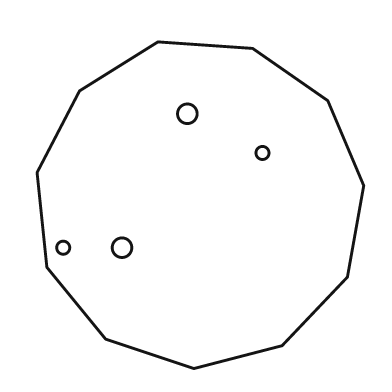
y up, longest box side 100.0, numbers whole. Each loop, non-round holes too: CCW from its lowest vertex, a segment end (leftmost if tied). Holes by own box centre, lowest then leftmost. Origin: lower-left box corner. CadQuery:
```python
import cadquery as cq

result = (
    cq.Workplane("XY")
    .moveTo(48.0, 0.0)
    .lineTo(75.0, 7.0)
    .lineTo(95.0, 28.0)
    .lineTo(100.0, 56.0)
    .lineTo(89.0, 82.0)
    .lineTo(66.0, 98.0)
    .lineTo(37.0, 100.0)
    .lineTo(13.0, 85.0)
    .lineTo(0.0, 60.0)
    .lineTo(3.0, 31.0)
    .lineTo(21.0, 9.0)
    .close()
    .moveTo(8.0, 37.0)
    .circle(2.0)
    .moveTo(26.0, 37.0)
    .circle(3.0)
    .moveTo(69.0, 66.0)
    .circle(2.0)
    .moveTo(46.0, 78.0)
    .circle(3.0)
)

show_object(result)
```